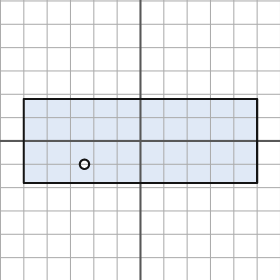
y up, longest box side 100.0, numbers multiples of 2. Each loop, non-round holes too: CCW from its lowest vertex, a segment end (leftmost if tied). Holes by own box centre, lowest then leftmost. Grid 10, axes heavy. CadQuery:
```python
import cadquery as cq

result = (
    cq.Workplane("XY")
    .moveTo(-50.0, -18.0)
    .lineTo(50.0, -18.0)
    .lineTo(50.0, 18.0)
    .lineTo(-50.0, 18.0)
    .close()
    .moveTo(-24.0, -10.0)
    .circle(2.0)
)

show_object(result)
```